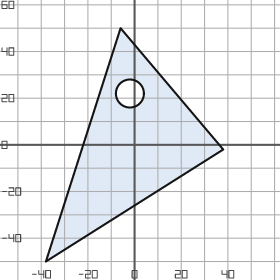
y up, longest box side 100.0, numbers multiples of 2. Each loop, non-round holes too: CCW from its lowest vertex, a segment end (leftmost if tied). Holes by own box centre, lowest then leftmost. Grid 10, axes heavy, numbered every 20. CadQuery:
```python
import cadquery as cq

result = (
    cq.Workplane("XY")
    .moveTo(-38.0, -50.0)
    .lineTo(38.0, -2.0)
    .lineTo(-6.0, 50.0)
    .close()
    .moveTo(-2.0, 22.0)
    .circle(6.0)
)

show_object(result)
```